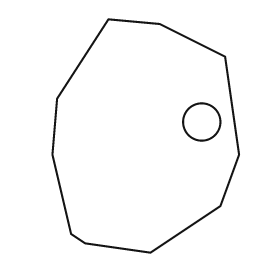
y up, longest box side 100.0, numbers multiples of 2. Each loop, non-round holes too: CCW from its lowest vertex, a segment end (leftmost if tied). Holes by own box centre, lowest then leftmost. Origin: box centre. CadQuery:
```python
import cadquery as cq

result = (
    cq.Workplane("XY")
    .moveTo(2.0, -50.0)
    .lineTo(32.0, -30.0)
    .lineTo(40.0, -8.0)
    .lineTo(34.0, 34.0)
    .lineTo(6.0, 48.0)
    .lineTo(-16.0, 50.0)
    .lineTo(-38.0, 16.0)
    .lineTo(-40.0, -8.0)
    .lineTo(-32.0, -42.0)
    .lineTo(-26.0, -46.0)
    .close()
    .moveTo(24.0, 6.0)
    .circle(8.0)
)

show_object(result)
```